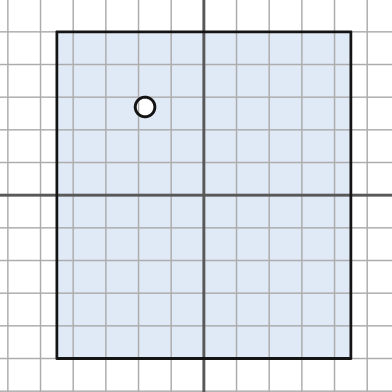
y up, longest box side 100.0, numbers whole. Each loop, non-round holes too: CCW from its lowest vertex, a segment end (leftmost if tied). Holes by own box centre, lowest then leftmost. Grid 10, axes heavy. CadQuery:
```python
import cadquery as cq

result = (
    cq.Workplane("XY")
    .moveTo(-45.0, -50.0)
    .lineTo(45.0, -50.0)
    .lineTo(45.0, 50.0)
    .lineTo(-45.0, 50.0)
    .close()
    .moveTo(-18.0, 27.0)
    .circle(3.0)
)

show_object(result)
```